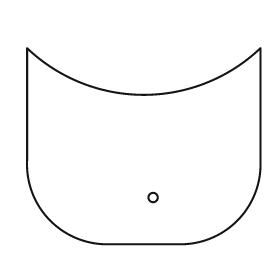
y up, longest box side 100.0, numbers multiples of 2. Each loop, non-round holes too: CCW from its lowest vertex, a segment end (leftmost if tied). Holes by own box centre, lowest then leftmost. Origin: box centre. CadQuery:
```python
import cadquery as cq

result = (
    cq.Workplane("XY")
    .moveTo(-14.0, -42.0)
    .lineTo(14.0, -42.0)
    .threePointArc((40.0, -32.0), (50.0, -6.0))
    .lineTo(50.0, 42.0)
    .threePointArc((0.0, 22.0), (-50.0, 42.0))
    .lineTo(-50.0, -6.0)
    .threePointArc((-40.0, -32.0), (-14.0, -42.0))
    .close()
    .moveTo(4.0, -22.0)
    .circle(2.0)
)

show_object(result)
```